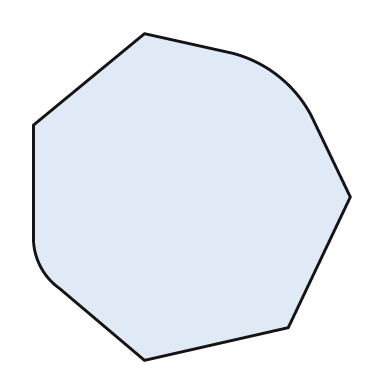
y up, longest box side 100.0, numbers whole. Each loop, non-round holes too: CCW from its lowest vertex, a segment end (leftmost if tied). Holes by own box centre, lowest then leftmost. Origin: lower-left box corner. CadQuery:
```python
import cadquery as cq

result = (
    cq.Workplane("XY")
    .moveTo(34.0, 0.0)
    .lineTo(78.0, 10.0)
    .lineTo(97.0, 50.0)
    .lineTo(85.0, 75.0)
    .threePointArc((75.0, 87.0), (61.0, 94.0))
    .lineTo(34.0, 100.0)
    .lineTo(0.0, 72.0)
    .lineTo(0.0, 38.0)
    .threePointArc((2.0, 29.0), (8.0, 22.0))
    .close()
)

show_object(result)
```